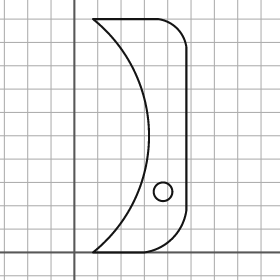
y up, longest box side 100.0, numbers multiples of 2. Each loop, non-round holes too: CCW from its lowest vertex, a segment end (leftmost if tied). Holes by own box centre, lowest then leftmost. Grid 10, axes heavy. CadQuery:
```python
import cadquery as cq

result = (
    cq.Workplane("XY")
    .moveTo(8.0, 0.0)
    .lineTo(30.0, 0.0)
    .threePointArc((42.0, 6.0), (48.0, 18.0))
    .lineTo(48.0, 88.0)
    .threePointArc((44.0, 96.0), (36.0, 100.0))
    .lineTo(8.0, 100.0)
    .threePointArc((32.0, 50.0), (8.0, 0.0))
    .close()
    .moveTo(38.0, 26.0)
    .circle(4.0)
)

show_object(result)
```